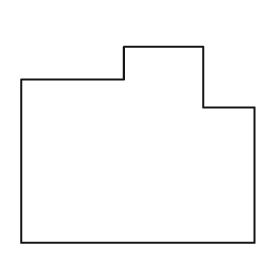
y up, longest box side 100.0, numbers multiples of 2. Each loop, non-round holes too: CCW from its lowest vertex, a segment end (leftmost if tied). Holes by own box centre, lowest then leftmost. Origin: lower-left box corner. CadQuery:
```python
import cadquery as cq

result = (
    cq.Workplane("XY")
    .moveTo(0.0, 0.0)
    .lineTo(100.0, 0.0)
    .lineTo(100.0, 58.0)
    .lineTo(78.0, 58.0)
    .lineTo(78.0, 84.0)
    .lineTo(44.0, 84.0)
    .lineTo(44.0, 70.0)
    .lineTo(0.0, 70.0)
    .close()
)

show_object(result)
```